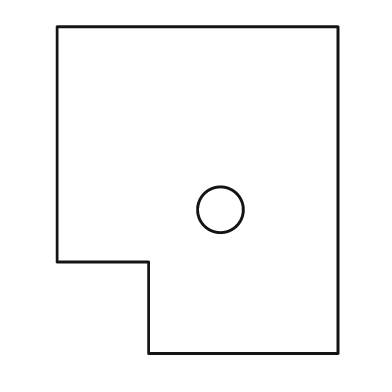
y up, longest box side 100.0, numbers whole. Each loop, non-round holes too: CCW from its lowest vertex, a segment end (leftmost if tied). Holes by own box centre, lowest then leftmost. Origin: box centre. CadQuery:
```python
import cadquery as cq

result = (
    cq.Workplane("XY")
    .moveTo(-15.0, -50.0)
    .lineTo(43.0, -50.0)
    .lineTo(43.0, 50.0)
    .lineTo(-43.0, 50.0)
    .lineTo(-43.0, -22.0)
    .lineTo(-15.0, -22.0)
    .close()
    .moveTo(7.0, -6.0)
    .circle(7.0)
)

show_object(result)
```